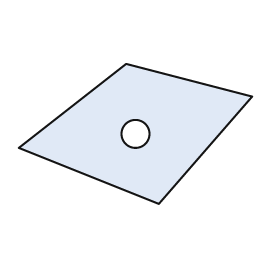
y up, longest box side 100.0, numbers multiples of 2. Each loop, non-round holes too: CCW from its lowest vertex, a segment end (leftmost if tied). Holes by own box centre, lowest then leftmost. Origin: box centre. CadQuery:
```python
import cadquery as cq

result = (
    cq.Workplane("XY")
    .moveTo(10.0, -30.0)
    .lineTo(50.0, 16.0)
    .lineTo(-4.0, 30.0)
    .lineTo(-50.0, -6.0)
    .close()
    .moveTo(0.0, 0.0)
    .circle(6.0)
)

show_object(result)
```